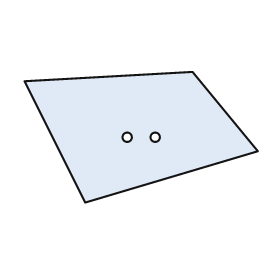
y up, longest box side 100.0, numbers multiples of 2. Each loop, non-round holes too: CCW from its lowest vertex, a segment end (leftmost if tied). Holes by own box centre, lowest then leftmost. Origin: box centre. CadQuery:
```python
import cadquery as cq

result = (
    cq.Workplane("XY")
    .moveTo(-24.0, -28.0)
    .lineTo(50.0, -6.0)
    .lineTo(22.0, 28.0)
    .lineTo(-50.0, 24.0)
    .close()
    .moveTo(-6.0, 0.0)
    .circle(2.0)
    .moveTo(6.0, 0.0)
    .circle(2.0)
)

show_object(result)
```